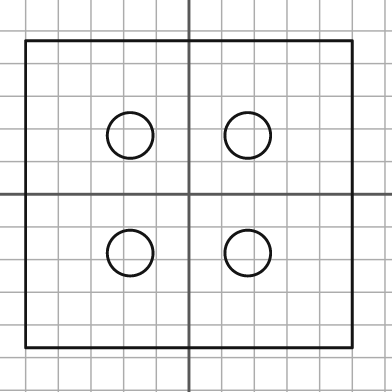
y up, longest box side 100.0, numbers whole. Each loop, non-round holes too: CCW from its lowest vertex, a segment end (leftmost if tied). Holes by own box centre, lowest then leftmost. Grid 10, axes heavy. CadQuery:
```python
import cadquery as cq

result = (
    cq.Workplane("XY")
    .moveTo(-50.0, -47.0)
    .lineTo(50.0, -47.0)
    .lineTo(50.0, 47.0)
    .lineTo(-50.0, 47.0)
    .close()
    .moveTo(-18.0, -18.0)
    .circle(7.0)
    .moveTo(18.0, -18.0)
    .circle(7.0)
    .moveTo(-18.0, 18.0)
    .circle(7.0)
    .moveTo(18.0, 18.0)
    .circle(7.0)
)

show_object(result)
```